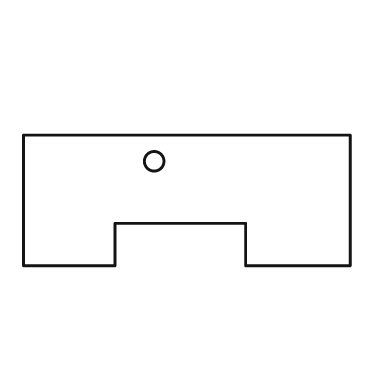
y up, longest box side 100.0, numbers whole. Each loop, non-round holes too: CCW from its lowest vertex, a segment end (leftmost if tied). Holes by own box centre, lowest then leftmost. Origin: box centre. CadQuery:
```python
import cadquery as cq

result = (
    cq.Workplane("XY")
    .moveTo(-50.0, -20.0)
    .lineTo(-22.0, -20.0)
    .lineTo(-22.0, -7.0)
    .lineTo(18.0, -7.0)
    .lineTo(18.0, -20.0)
    .lineTo(50.0, -20.0)
    .lineTo(50.0, 20.0)
    .lineTo(-50.0, 20.0)
    .close()
    .moveTo(-10.0, 12.0)
    .circle(3.0)
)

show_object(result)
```